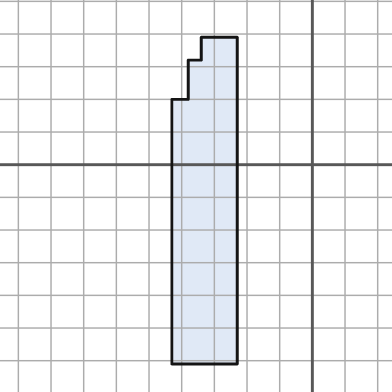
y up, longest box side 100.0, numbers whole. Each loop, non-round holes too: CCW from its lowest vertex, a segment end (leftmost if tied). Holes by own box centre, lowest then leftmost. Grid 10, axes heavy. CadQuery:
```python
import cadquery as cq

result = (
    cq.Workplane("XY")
    .moveTo(-43.0, -61.0)
    .lineTo(-23.0, -61.0)
    .lineTo(-23.0, 39.0)
    .lineTo(-34.0, 39.0)
    .lineTo(-34.0, 32.0)
    .lineTo(-38.0, 32.0)
    .lineTo(-38.0, 20.0)
    .lineTo(-43.0, 20.0)
    .close()
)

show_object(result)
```